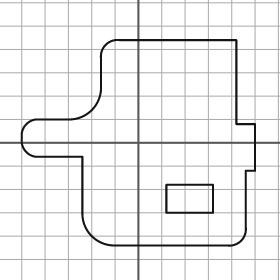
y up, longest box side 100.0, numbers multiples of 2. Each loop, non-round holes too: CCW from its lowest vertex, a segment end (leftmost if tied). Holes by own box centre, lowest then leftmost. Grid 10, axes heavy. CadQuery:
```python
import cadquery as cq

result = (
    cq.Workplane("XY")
    .moveTo(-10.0, -44.0)
    .lineTo(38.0, -44.0)
    .threePointArc((44.0, -42.0), (46.0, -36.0))
    .lineTo(46.0, -12.0)
    .lineTo(50.0, -12.0)
    .lineTo(50.0, 8.0)
    .lineTo(42.0, 8.0)
    .lineTo(42.0, 44.0)
    .lineTo(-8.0, 44.0)
    .threePointArc((-14.0, 42.0), (-16.0, 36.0))
    .lineTo(-16.0, 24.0)
    .threePointArc((-20.0, 14.0), (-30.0, 10.0))
    .lineTo(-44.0, 10.0)
    .threePointArc((-48.0, 8.0), (-50.0, 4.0))
    .lineTo(-50.0, 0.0)
    .threePointArc((-48.0, -4.0), (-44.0, -6.0))
    .lineTo(-24.0, -6.0)
    .lineTo(-24.0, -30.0)
    .threePointArc((-20.0, -40.0), (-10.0, -44.0))
    .close()
    .moveTo(12.0, -30.0)
    .lineTo(32.0, -30.0)
    .lineTo(32.0, -18.0)
    .lineTo(12.0, -18.0)
    .close()
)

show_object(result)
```